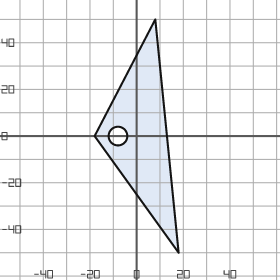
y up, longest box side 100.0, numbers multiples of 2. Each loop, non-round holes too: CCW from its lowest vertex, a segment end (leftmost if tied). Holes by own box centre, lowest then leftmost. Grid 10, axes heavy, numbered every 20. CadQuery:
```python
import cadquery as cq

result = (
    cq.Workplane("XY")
    .moveTo(18.0, -50.0)
    .lineTo(8.0, 50.0)
    .lineTo(-18.0, 0.0)
    .close()
    .moveTo(-8.0, 0.0)
    .circle(4.0)
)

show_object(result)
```